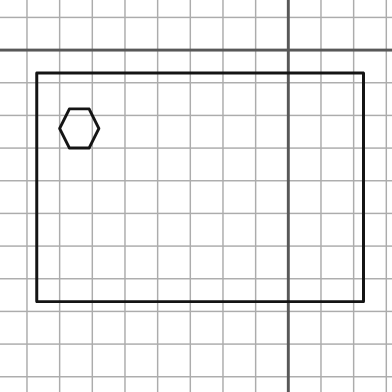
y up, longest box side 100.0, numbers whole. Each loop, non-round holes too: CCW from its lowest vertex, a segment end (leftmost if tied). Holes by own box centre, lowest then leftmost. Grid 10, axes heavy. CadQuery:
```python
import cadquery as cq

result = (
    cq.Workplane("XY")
    .moveTo(-77.0, -77.0)
    .lineTo(23.0, -77.0)
    .lineTo(23.0, -7.0)
    .lineTo(-77.0, -7.0)
    .close()
    .moveTo(-67.0, -30.0)
    .lineTo(-61.0, -30.0)
    .lineTo(-58.0, -24.0)
    .lineTo(-61.0, -18.0)
    .lineTo(-67.0, -18.0)
    .lineTo(-70.0, -24.0)
    .close()
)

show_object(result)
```